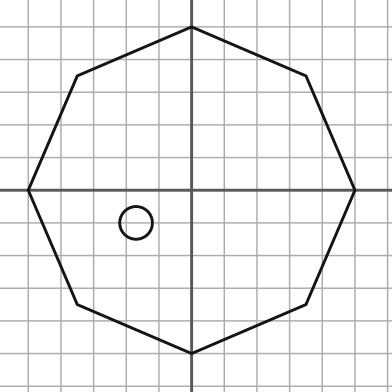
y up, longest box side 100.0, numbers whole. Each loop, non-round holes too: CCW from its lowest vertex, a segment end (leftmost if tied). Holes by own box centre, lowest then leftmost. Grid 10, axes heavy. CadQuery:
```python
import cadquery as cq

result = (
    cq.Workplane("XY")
    .moveTo(0.0, -50.0)
    .lineTo(35.0, -35.0)
    .lineTo(50.0, 0.0)
    .lineTo(35.0, 35.0)
    .lineTo(0.0, 50.0)
    .lineTo(-35.0, 35.0)
    .lineTo(-50.0, 0.0)
    .lineTo(-35.0, -35.0)
    .close()
    .moveTo(-17.0, -10.0)
    .circle(5.0)
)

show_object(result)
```